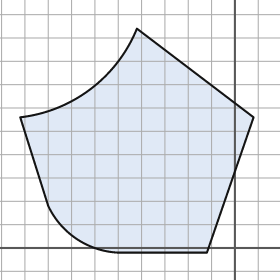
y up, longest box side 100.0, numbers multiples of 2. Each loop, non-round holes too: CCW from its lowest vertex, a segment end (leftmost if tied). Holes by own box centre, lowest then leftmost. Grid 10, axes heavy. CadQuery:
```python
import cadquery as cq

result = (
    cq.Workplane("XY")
    .moveTo(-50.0, -2.0)
    .lineTo(-12.0, -2.0)
    .lineTo(8.0, 56.0)
    .lineTo(-42.0, 94.0)
    .threePointArc((-62.0, 68.0), (-92.0, 56.0))
    .lineTo(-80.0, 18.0)
    .threePointArc((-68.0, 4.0), (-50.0, -2.0))
    .close()
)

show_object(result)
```